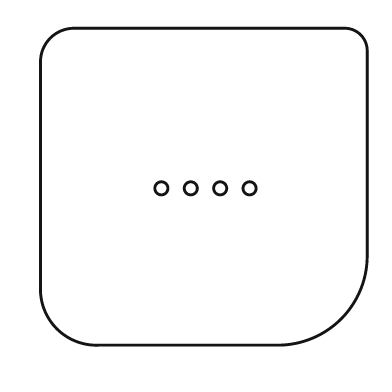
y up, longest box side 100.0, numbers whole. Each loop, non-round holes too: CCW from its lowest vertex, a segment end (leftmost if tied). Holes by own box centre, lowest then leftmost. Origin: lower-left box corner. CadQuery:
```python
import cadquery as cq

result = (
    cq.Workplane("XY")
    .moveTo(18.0, 0.0)
    .lineTo(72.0, 0.0)
    .threePointArc((92.0, 8.0), (100.0, 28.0))
    .lineTo(100.0, 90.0)
    .threePointArc((98.0, 95.0), (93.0, 97.0))
    .lineTo(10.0, 97.0)
    .threePointArc((3.0, 94.0), (0.0, 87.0))
    .lineTo(0.0, 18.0)
    .threePointArc((5.0, 5.0), (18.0, 0.0))
    .close()
    .moveTo(37.0, 48.0)
    .circle(2.0)
    .moveTo(46.0, 48.0)
    .circle(2.0)
    .moveTo(55.0, 48.0)
    .circle(2.0)
    .moveTo(64.0, 48.0)
    .circle(2.0)
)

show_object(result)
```